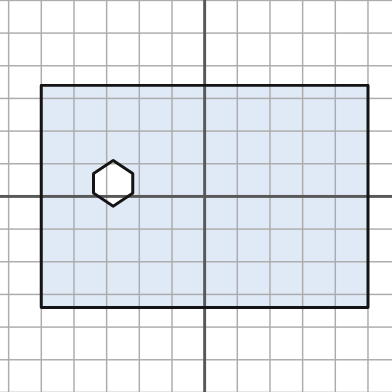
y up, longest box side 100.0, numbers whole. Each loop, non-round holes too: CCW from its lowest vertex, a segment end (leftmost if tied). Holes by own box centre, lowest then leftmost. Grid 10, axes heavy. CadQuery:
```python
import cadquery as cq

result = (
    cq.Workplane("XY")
    .moveTo(-50.0, -34.0)
    .lineTo(50.0, -34.0)
    .lineTo(50.0, 34.0)
    .lineTo(-50.0, 34.0)
    .close()
    .moveTo(-28.0, -3.0)
    .lineTo(-22.0, 1.0)
    .lineTo(-22.0, 7.0)
    .lineTo(-28.0, 11.0)
    .lineTo(-34.0, 7.0)
    .lineTo(-34.0, 1.0)
    .close()
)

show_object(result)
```